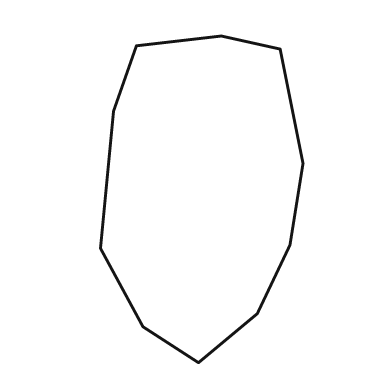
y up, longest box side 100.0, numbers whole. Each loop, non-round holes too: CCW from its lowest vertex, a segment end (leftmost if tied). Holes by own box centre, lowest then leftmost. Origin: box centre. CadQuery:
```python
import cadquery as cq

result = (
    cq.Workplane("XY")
    .moveTo(-1.0, -50.0)
    .lineTo(17.0, -35.0)
    .lineTo(27.0, -14.0)
    .lineTo(31.0, 11.0)
    .lineTo(24.0, 46.0)
    .lineTo(6.0, 50.0)
    .lineTo(-20.0, 47.0)
    .lineTo(-27.0, 27.0)
    .lineTo(-31.0, -15.0)
    .lineTo(-18.0, -39.0)
    .close()
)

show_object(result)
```